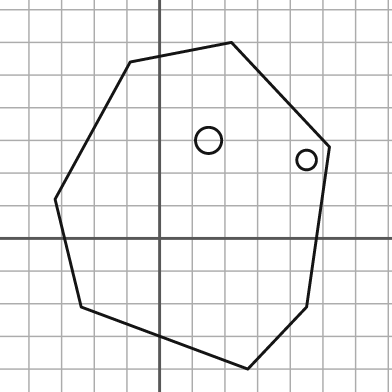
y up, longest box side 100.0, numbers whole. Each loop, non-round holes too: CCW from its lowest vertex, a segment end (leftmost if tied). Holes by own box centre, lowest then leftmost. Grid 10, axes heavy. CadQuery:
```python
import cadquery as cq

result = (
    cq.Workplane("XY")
    .moveTo(27.0, -40.0)
    .lineTo(45.0, -21.0)
    .lineTo(52.0, 28.0)
    .lineTo(22.0, 60.0)
    .lineTo(-9.0, 54.0)
    .lineTo(-32.0, 12.0)
    .lineTo(-24.0, -21.0)
    .close()
    .moveTo(45.0, 24.0)
    .circle(3.0)
    .moveTo(15.0, 30.0)
    .circle(4.0)
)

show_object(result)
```